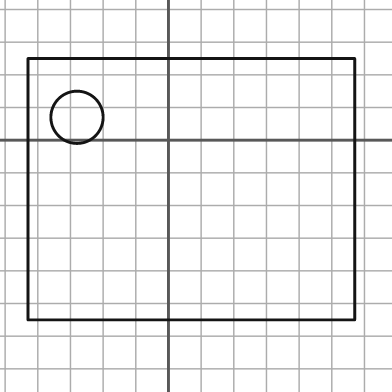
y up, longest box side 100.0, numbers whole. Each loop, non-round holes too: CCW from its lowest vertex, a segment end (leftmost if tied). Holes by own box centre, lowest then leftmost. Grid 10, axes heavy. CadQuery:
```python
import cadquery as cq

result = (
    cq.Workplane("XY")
    .moveTo(-43.0, -55.0)
    .lineTo(57.0, -55.0)
    .lineTo(57.0, 25.0)
    .lineTo(-43.0, 25.0)
    .close()
    .moveTo(-28.0, 7.0)
    .circle(8.0)
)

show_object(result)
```